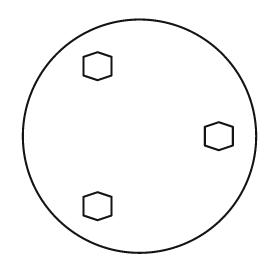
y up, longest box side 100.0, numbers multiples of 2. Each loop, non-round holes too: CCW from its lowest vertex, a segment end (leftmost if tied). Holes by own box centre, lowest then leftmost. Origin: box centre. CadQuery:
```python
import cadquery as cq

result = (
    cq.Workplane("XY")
    .moveTo(0.0, 0.0)
    .circle(50.0)
    .moveTo(-18.0, -36.0)
    .lineTo(-12.0, -34.0)
    .lineTo(-12.0, -26.0)
    .lineTo(-18.0, -24.0)
    .lineTo(-24.0, -26.0)
    .lineTo(-24.0, -34.0)
    .close()
    .moveTo(34.0, -6.0)
    .lineTo(40.0, -4.0)
    .lineTo(40.0, 4.0)
    .lineTo(34.0, 6.0)
    .lineTo(28.0, 4.0)
    .lineTo(28.0, -4.0)
    .close()
    .moveTo(-18.0, 24.0)
    .lineTo(-12.0, 26.0)
    .lineTo(-12.0, 34.0)
    .lineTo(-18.0, 36.0)
    .lineTo(-24.0, 34.0)
    .lineTo(-24.0, 26.0)
    .close()
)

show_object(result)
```